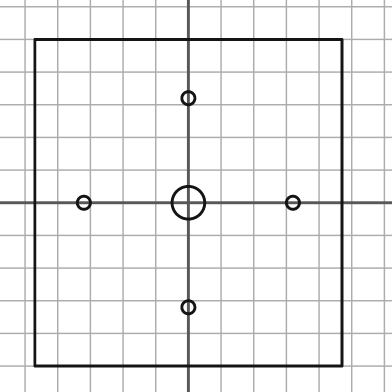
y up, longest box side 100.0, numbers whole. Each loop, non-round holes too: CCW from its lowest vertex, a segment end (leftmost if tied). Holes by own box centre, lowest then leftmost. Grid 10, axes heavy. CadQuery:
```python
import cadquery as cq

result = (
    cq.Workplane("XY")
    .moveTo(-47.0, -50.0)
    .lineTo(47.0, -50.0)
    .lineTo(47.0, 50.0)
    .lineTo(-47.0, 50.0)
    .close()
    .moveTo(0.0, -32.0)
    .circle(2.0)
    .moveTo(-32.0, 0.0)
    .circle(2.0)
    .moveTo(0.0, 0.0)
    .circle(5.0)
    .moveTo(32.0, 0.0)
    .circle(2.0)
    .moveTo(0.0, 32.0)
    .circle(2.0)
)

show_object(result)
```